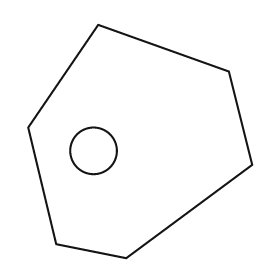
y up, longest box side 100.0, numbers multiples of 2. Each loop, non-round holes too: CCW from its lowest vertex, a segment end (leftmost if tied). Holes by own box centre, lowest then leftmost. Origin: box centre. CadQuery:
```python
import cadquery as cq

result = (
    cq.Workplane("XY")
    .moveTo(-6.0, -50.0)
    .lineTo(48.0, -10.0)
    .lineTo(38.0, 30.0)
    .lineTo(-18.0, 50.0)
    .lineTo(-48.0, 6.0)
    .lineTo(-36.0, -44.0)
    .close()
    .moveTo(-20.0, -4.0)
    .circle(10.0)
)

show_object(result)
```